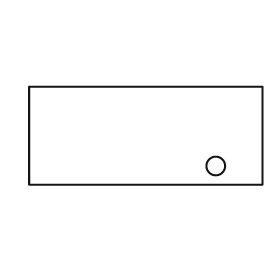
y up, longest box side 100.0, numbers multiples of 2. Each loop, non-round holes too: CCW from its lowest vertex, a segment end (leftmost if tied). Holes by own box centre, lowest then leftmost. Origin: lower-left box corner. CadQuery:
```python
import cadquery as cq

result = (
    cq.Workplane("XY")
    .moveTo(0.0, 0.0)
    .lineTo(100.0, 0.0)
    .lineTo(100.0, 42.0)
    .lineTo(0.0, 42.0)
    .close()
    .moveTo(80.0, 8.0)
    .circle(4.0)
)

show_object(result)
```